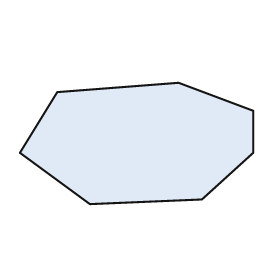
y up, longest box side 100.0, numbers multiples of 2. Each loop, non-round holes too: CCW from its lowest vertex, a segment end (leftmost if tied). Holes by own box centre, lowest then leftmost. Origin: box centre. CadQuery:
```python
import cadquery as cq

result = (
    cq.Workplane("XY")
    .moveTo(-20.0, -26.0)
    .lineTo(28.0, -24.0)
    .lineTo(50.0, -4.0)
    .lineTo(50.0, 14.0)
    .lineTo(18.0, 26.0)
    .lineTo(-34.0, 22.0)
    .lineTo(-50.0, -4.0)
    .close()
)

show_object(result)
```